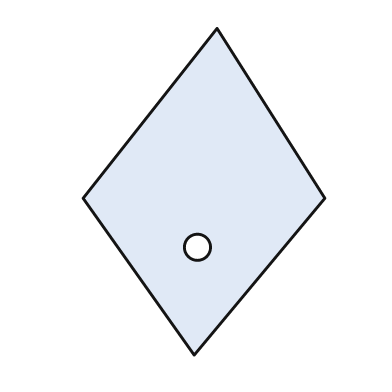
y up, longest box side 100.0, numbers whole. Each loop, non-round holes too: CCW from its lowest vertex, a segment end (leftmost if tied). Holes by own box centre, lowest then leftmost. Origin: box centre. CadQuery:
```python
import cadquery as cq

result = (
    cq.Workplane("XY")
    .moveTo(-3.0, -50.0)
    .lineTo(37.0, -2.0)
    .lineTo(4.0, 50.0)
    .lineTo(-37.0, -2.0)
    .close()
    .moveTo(-2.0, -17.0)
    .circle(4.0)
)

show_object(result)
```